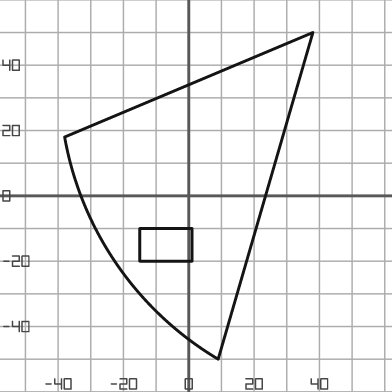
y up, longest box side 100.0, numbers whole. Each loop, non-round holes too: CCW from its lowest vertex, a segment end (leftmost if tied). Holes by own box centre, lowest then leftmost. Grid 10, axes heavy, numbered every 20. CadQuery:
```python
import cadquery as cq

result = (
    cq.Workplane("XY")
    .moveTo(9.0, -50.0)
    .lineTo(38.0, 50.0)
    .lineTo(-38.0, 18.0)
    .threePointArc((-22.0, -21.0), (9.0, -50.0))
    .close()
    .moveTo(-15.0, -20.0)
    .lineTo(1.0, -20.0)
    .lineTo(1.0, -10.0)
    .lineTo(-15.0, -10.0)
    .close()
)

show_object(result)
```